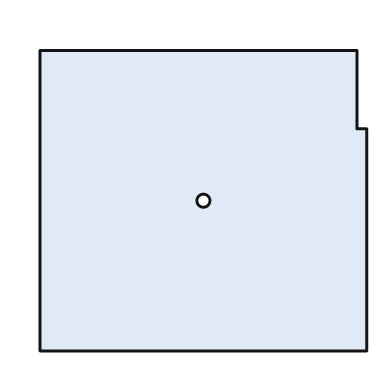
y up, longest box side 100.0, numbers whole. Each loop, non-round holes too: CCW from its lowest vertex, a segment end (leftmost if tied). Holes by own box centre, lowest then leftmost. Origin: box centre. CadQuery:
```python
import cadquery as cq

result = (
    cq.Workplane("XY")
    .moveTo(-50.0, -46.0)
    .lineTo(50.0, -46.0)
    .lineTo(50.0, 22.0)
    .lineTo(47.0, 22.0)
    .lineTo(47.0, 46.0)
    .lineTo(-50.0, 46.0)
    .close()
    .moveTo(0.0, 0.0)
    .circle(2.0)
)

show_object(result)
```